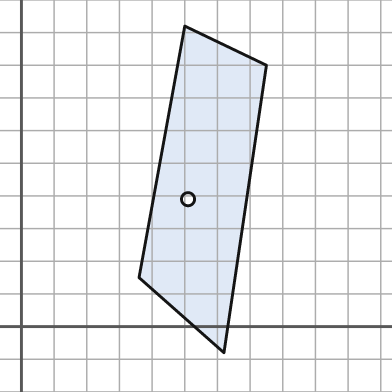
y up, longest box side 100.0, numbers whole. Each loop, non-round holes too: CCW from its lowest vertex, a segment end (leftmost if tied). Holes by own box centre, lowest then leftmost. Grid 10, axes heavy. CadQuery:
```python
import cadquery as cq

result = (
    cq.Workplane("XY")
    .moveTo(62.0, -8.0)
    .lineTo(75.0, 80.0)
    .lineTo(50.0, 92.0)
    .lineTo(36.0, 15.0)
    .close()
    .moveTo(51.0, 39.0)
    .circle(2.0)
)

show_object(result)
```